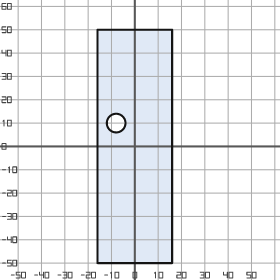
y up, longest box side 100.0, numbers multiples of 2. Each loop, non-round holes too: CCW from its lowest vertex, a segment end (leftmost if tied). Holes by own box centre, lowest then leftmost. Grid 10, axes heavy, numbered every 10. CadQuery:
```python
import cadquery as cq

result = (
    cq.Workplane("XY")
    .moveTo(-16.0, -50.0)
    .lineTo(16.0, -50.0)
    .lineTo(16.0, 50.0)
    .lineTo(-16.0, 50.0)
    .close()
    .moveTo(-8.0, 10.0)
    .circle(4.0)
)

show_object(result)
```